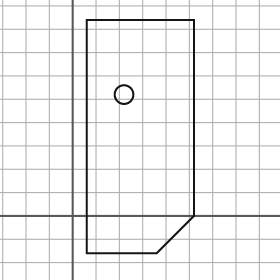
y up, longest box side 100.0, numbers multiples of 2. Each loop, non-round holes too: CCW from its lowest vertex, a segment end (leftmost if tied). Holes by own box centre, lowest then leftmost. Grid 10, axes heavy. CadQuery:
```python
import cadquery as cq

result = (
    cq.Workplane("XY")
    .moveTo(6.0, -16.0)
    .lineTo(36.0, -16.0)
    .lineTo(52.0, 0.0)
    .lineTo(52.0, 84.0)
    .lineTo(6.0, 84.0)
    .close()
    .moveTo(22.0, 52.0)
    .circle(4.0)
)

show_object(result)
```